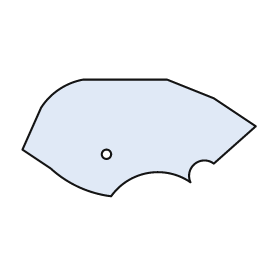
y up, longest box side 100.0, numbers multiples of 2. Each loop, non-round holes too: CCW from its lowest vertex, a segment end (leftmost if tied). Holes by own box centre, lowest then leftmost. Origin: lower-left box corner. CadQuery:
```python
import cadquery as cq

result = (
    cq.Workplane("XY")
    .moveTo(38.0, 0.0)
    .threePointArc((54.0, 10.0), (72.0, 6.0))
    .threePointArc((74.0, 14.0), (82.0, 14.0))
    .lineTo(100.0, 30.0)
    .lineTo(82.0, 42.0)
    .lineTo(62.0, 50.0)
    .lineTo(26.0, 50.0)
    .threePointArc((16.0, 46.0), (8.0, 38.0))
    .lineTo(0.0, 20.0)
    .lineTo(12.0, 12.0)
    .threePointArc((24.0, 4.0), (38.0, 0.0))
    .close()
    .moveTo(36.0, 18.0)
    .circle(2.0)
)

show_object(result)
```